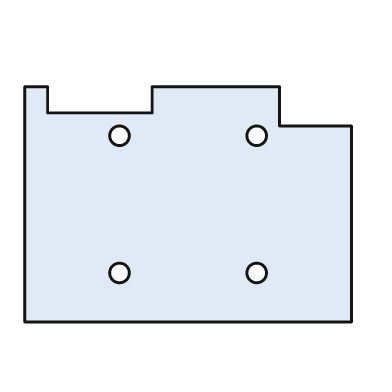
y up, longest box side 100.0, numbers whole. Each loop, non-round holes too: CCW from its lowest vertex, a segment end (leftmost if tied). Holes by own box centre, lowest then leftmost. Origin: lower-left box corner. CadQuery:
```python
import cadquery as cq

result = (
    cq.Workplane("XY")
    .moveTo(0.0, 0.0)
    .lineTo(100.0, 0.0)
    .lineTo(100.0, 60.0)
    .lineTo(78.0, 60.0)
    .lineTo(78.0, 72.0)
    .lineTo(39.0, 72.0)
    .lineTo(39.0, 64.0)
    .lineTo(7.0, 64.0)
    .lineTo(7.0, 72.0)
    .lineTo(0.0, 72.0)
    .close()
    .moveTo(29.0, 15.0)
    .circle(3.0)
    .moveTo(71.0, 15.0)
    .circle(3.0)
    .moveTo(29.0, 57.0)
    .circle(3.0)
    .moveTo(71.0, 57.0)
    .circle(3.0)
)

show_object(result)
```